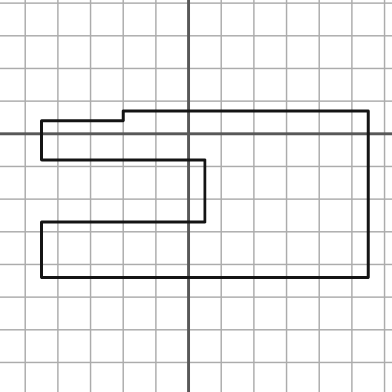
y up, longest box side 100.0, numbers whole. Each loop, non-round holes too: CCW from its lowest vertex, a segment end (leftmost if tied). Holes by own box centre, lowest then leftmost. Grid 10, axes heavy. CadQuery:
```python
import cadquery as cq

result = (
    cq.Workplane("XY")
    .moveTo(-45.0, -44.0)
    .lineTo(55.0, -44.0)
    .lineTo(55.0, 7.0)
    .lineTo(-20.0, 7.0)
    .lineTo(-20.0, 4.0)
    .lineTo(-45.0, 4.0)
    .lineTo(-45.0, -8.0)
    .lineTo(5.0, -8.0)
    .lineTo(5.0, -27.0)
    .lineTo(-45.0, -27.0)
    .close()
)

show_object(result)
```